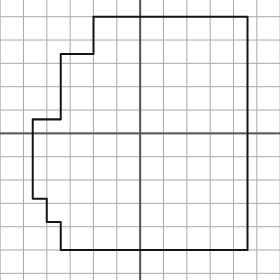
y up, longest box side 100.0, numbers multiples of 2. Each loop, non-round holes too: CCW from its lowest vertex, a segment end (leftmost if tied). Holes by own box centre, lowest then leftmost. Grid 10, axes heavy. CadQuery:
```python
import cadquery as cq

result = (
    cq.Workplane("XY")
    .moveTo(-34.0, -50.0)
    .lineTo(46.0, -50.0)
    .lineTo(46.0, 50.0)
    .lineTo(-20.0, 50.0)
    .lineTo(-20.0, 34.0)
    .lineTo(-34.0, 34.0)
    .lineTo(-34.0, 6.0)
    .lineTo(-46.0, 6.0)
    .lineTo(-46.0, -28.0)
    .lineTo(-40.0, -28.0)
    .lineTo(-40.0, -38.0)
    .lineTo(-34.0, -38.0)
    .close()
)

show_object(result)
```